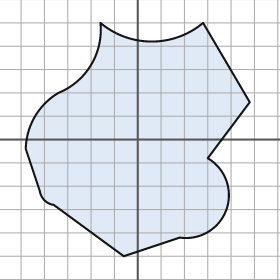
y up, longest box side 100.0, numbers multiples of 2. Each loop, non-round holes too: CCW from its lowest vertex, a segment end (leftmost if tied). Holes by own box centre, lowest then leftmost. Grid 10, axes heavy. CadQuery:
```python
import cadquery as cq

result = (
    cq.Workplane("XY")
    .moveTo(-6.0, -50.0)
    .lineTo(18.0, -42.0)
    .threePointArc((38.0, -30.0), (30.0, -8.0))
    .lineTo(48.0, 16.0)
    .lineTo(28.0, 50.0)
    .threePointArc((6.0, 42.0), (-16.0, 50.0))
    .threePointArc((-20.0, 32.0), (-34.0, 20.0))
    .threePointArc((-44.0, 10.0), (-48.0, -4.0))
    .lineTo(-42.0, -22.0)
    .threePointArc((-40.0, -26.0), (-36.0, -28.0))
    .close()
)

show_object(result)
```